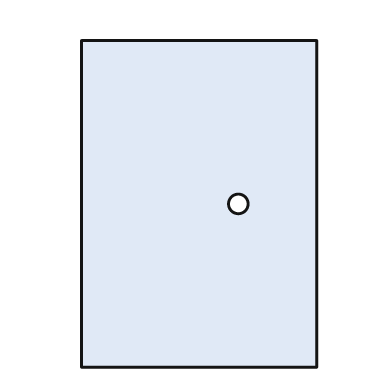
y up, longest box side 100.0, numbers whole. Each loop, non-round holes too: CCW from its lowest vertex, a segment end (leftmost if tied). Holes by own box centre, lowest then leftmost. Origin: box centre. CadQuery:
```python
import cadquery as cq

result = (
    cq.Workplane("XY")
    .moveTo(-36.0, -50.0)
    .lineTo(36.0, -50.0)
    .lineTo(36.0, 50.0)
    .lineTo(-36.0, 50.0)
    .close()
    .moveTo(12.0, 0.0)
    .circle(3.0)
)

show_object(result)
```